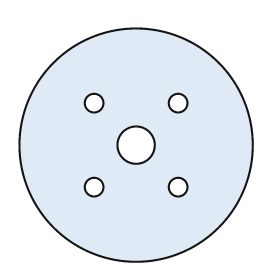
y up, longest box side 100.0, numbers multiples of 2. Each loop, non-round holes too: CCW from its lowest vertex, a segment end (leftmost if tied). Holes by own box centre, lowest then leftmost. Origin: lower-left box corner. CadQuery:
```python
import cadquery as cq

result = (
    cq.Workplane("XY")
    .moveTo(50.0, 50.0)
    .circle(50.0)
    .moveTo(32.0, 32.0)
    .circle(4.0)
    .moveTo(68.0, 32.0)
    .circle(4.0)
    .moveTo(50.0, 50.0)
    .circle(8.0)
    .moveTo(32.0, 68.0)
    .circle(4.0)
    .moveTo(68.0, 68.0)
    .circle(4.0)
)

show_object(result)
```